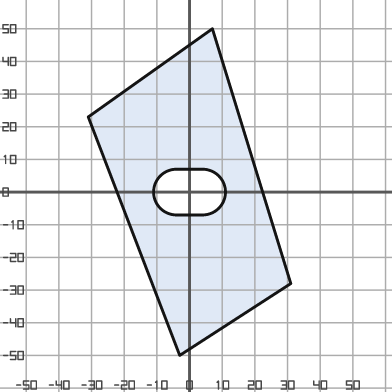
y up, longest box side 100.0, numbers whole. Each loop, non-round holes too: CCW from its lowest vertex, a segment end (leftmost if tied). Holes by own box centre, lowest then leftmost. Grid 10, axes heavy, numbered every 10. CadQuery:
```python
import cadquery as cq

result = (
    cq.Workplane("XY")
    .moveTo(-3.0, -50.0)
    .lineTo(31.0, -28.0)
    .lineTo(7.0, 50.0)
    .lineTo(-31.0, 23.0)
    .close()
    .moveTo(-4.0, -7.0)
    .lineTo(4.0, -7.0)
    .threePointArc((11.0, 0.0), (4.0, 7.0))
    .lineTo(-4.0, 7.0)
    .threePointArc((-11.0, 0.0), (-4.0, -7.0))
    .close()
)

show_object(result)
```